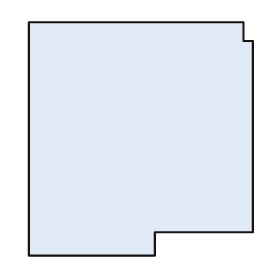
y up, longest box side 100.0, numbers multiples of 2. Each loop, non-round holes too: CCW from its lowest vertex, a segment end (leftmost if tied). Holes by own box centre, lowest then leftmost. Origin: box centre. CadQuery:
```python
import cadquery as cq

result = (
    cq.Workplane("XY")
    .moveTo(-48.0, -50.0)
    .lineTo(6.0, -50.0)
    .lineTo(6.0, -40.0)
    .lineTo(48.0, -40.0)
    .lineTo(48.0, 42.0)
    .lineTo(44.0, 42.0)
    .lineTo(44.0, 50.0)
    .lineTo(-48.0, 50.0)
    .close()
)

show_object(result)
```